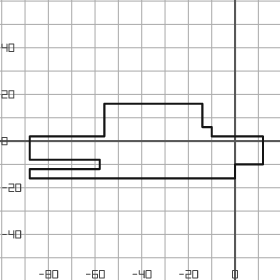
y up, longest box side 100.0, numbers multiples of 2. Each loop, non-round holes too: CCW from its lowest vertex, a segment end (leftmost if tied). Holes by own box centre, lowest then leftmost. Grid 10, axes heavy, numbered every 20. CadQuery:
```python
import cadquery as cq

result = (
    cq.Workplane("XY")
    .moveTo(-88.0, -16.0)
    .lineTo(0.0, -16.0)
    .lineTo(0.0, -10.0)
    .lineTo(12.0, -10.0)
    .lineTo(12.0, 2.0)
    .lineTo(-10.0, 2.0)
    .lineTo(-10.0, 6.0)
    .lineTo(-14.0, 6.0)
    .lineTo(-14.0, 16.0)
    .lineTo(-56.0, 16.0)
    .lineTo(-56.0, 2.0)
    .lineTo(-88.0, 2.0)
    .lineTo(-88.0, -8.0)
    .lineTo(-58.0, -8.0)
    .lineTo(-58.0, -12.0)
    .lineTo(-88.0, -12.0)
    .close()
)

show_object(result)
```